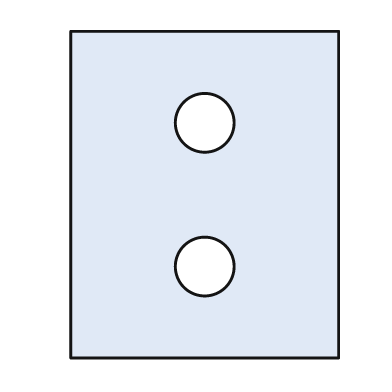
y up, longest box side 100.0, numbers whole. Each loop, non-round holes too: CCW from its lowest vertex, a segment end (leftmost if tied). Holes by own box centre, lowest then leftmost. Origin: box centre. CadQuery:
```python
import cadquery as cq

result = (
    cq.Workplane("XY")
    .moveTo(-41.0, -50.0)
    .lineTo(41.0, -50.0)
    .lineTo(41.0, 50.0)
    .lineTo(-41.0, 50.0)
    .close()
    .moveTo(0.0, -22.0)
    .circle(9.0)
    .moveTo(0.0, 22.0)
    .circle(9.0)
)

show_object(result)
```